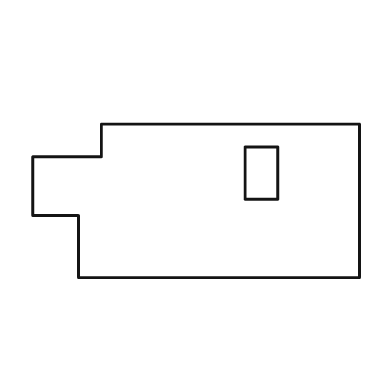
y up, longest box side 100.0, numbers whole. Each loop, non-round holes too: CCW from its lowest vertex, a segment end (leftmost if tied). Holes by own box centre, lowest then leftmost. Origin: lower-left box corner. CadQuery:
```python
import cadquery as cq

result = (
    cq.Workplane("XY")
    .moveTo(14.0, 0.0)
    .lineTo(100.0, 0.0)
    .lineTo(100.0, 47.0)
    .lineTo(21.0, 47.0)
    .lineTo(21.0, 37.0)
    .lineTo(0.0, 37.0)
    .lineTo(0.0, 19.0)
    .lineTo(14.0, 19.0)
    .close()
    .moveTo(65.0, 24.0)
    .lineTo(75.0, 24.0)
    .lineTo(75.0, 40.0)
    .lineTo(65.0, 40.0)
    .close()
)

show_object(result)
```